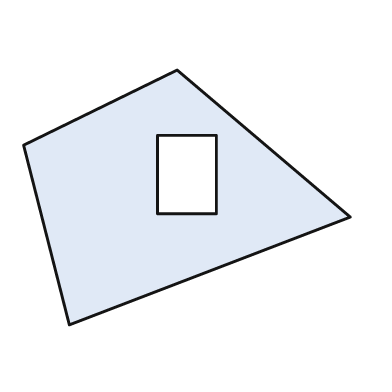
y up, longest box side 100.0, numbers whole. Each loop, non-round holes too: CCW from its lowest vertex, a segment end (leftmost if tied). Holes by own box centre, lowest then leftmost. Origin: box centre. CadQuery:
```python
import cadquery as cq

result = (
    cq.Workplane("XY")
    .moveTo(-36.0, -39.0)
    .lineTo(50.0, -6.0)
    .lineTo(-3.0, 39.0)
    .lineTo(-50.0, 16.0)
    .close()
    .moveTo(-9.0, -5.0)
    .lineTo(9.0, -5.0)
    .lineTo(9.0, 19.0)
    .lineTo(-9.0, 19.0)
    .close()
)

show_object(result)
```